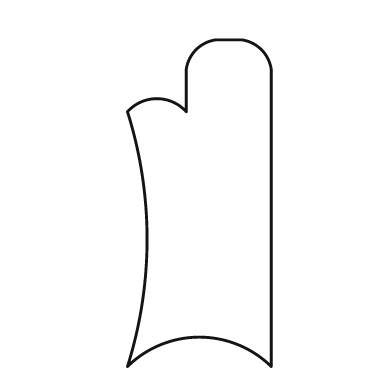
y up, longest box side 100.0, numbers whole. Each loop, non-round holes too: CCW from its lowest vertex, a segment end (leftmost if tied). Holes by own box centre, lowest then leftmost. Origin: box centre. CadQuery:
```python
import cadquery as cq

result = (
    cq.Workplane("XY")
    .moveTo(-22.0, -50.0)
    .threePointArc((0.0, -41.0), (22.0, -50.0))
    .lineTo(22.0, 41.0)
    .threePointArc((19.0, 47.0), (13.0, 50.0))
    .lineTo(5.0, 50.0)
    .threePointArc((-1.0, 47.0), (-4.0, 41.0))
    .lineTo(-4.0, 28.0)
    .threePointArc((-13.0, 32.0), (-22.0, 28.0))
    .threePointArc((-16.0, -11.0), (-22.0, -50.0))
    .close()
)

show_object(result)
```